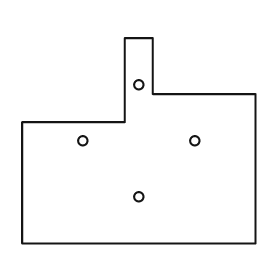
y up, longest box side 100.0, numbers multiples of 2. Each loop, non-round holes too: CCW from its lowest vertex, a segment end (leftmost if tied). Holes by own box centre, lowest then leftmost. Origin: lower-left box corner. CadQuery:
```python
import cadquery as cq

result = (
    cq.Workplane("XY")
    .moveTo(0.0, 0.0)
    .lineTo(100.0, 0.0)
    .lineTo(100.0, 64.0)
    .lineTo(56.0, 64.0)
    .lineTo(56.0, 88.0)
    .lineTo(44.0, 88.0)
    .lineTo(44.0, 52.0)
    .lineTo(0.0, 52.0)
    .close()
    .moveTo(50.0, 20.0)
    .circle(2.0)
    .moveTo(26.0, 44.0)
    .circle(2.0)
    .moveTo(74.0, 44.0)
    .circle(2.0)
    .moveTo(50.0, 68.0)
    .circle(2.0)
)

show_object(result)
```